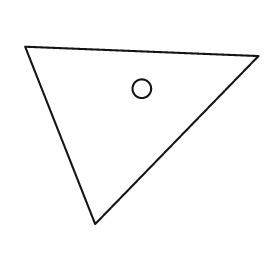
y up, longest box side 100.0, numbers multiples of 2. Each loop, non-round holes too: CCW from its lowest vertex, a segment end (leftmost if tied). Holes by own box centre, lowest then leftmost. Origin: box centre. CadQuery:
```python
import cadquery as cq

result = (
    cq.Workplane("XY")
    .moveTo(-20.0, -38.0)
    .lineTo(50.0, 34.0)
    .lineTo(-50.0, 38.0)
    .close()
    .moveTo(0.0, 20.0)
    .circle(4.0)
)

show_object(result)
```